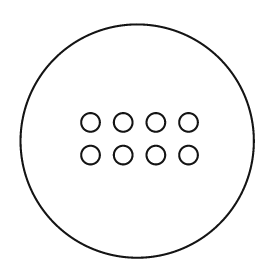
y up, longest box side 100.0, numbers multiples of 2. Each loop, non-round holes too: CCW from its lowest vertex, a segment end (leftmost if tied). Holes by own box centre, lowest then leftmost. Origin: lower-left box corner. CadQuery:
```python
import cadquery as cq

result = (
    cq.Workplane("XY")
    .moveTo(50.0, 50.0)
    .circle(50.0)
    .moveTo(30.0, 44.0)
    .circle(4.0)
    .moveTo(44.0, 44.0)
    .circle(4.0)
    .moveTo(58.0, 44.0)
    .circle(4.0)
    .moveTo(72.0, 44.0)
    .circle(4.0)
    .moveTo(30.0, 58.0)
    .circle(4.0)
    .moveTo(44.0, 58.0)
    .circle(4.0)
    .moveTo(58.0, 58.0)
    .circle(4.0)
    .moveTo(72.0, 58.0)
    .circle(4.0)
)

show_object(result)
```